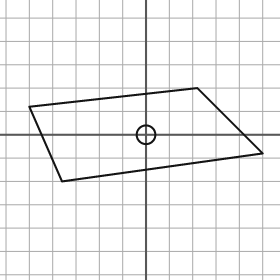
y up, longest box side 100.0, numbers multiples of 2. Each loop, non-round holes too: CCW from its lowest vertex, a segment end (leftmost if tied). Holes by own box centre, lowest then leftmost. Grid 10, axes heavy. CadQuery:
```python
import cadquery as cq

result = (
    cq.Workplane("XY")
    .moveTo(-36.0, -20.0)
    .lineTo(50.0, -8.0)
    .lineTo(22.0, 20.0)
    .lineTo(-50.0, 12.0)
    .close()
    .moveTo(0.0, 0.0)
    .circle(4.0)
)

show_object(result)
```